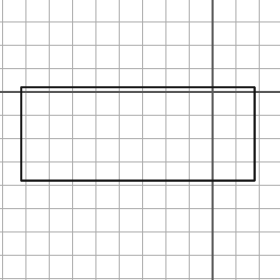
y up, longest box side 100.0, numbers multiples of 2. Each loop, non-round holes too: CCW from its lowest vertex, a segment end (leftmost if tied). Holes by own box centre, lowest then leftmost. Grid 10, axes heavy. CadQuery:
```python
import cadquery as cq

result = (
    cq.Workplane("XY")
    .moveTo(-82.0, -38.0)
    .lineTo(18.0, -38.0)
    .lineTo(18.0, 2.0)
    .lineTo(-82.0, 2.0)
    .close()
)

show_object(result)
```